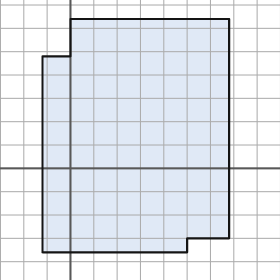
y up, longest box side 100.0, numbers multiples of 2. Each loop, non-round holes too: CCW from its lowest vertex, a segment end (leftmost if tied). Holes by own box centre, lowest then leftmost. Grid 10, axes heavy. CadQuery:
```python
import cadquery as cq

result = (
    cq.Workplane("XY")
    .moveTo(-12.0, -36.0)
    .lineTo(50.0, -36.0)
    .lineTo(50.0, -30.0)
    .lineTo(68.0, -30.0)
    .lineTo(68.0, 64.0)
    .lineTo(0.0, 64.0)
    .lineTo(0.0, 48.0)
    .lineTo(-12.0, 48.0)
    .close()
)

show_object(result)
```